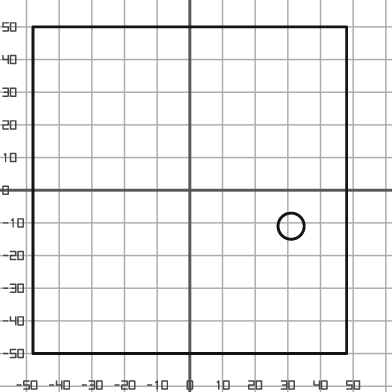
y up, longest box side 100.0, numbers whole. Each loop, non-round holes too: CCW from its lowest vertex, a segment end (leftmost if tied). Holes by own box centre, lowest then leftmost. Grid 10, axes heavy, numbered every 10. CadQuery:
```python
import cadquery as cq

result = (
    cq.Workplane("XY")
    .moveTo(-48.0, -50.0)
    .lineTo(48.0, -50.0)
    .lineTo(48.0, 50.0)
    .lineTo(-48.0, 50.0)
    .close()
    .moveTo(31.0, -11.0)
    .circle(4.0)
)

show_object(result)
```